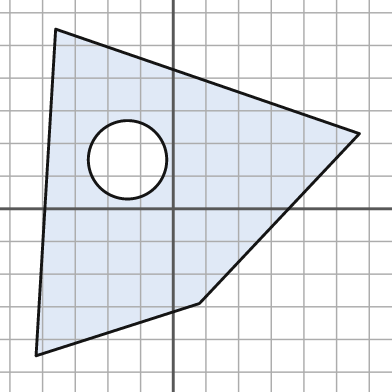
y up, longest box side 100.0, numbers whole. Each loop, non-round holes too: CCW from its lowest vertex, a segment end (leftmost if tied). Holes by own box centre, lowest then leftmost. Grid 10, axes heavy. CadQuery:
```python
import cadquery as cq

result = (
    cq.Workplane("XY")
    .moveTo(-42.0, -45.0)
    .lineTo(8.0, -29.0)
    .lineTo(57.0, 23.0)
    .lineTo(-36.0, 55.0)
    .close()
    .moveTo(-14.0, 15.0)
    .circle(12.0)
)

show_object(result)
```